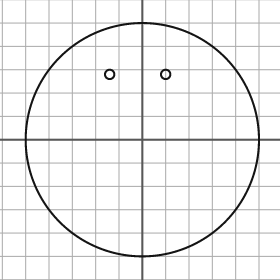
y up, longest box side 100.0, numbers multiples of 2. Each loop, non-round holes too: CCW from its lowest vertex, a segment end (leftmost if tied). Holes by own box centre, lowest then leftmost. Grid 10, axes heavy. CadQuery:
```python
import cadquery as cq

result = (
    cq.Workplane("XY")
    .moveTo(0.0, 0.0)
    .circle(50.0)
    .moveTo(-14.0, 28.0)
    .circle(2.0)
    .moveTo(10.0, 28.0)
    .circle(2.0)
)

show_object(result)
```